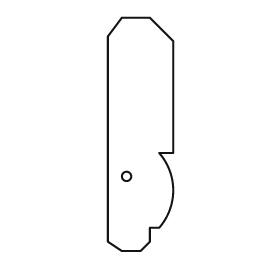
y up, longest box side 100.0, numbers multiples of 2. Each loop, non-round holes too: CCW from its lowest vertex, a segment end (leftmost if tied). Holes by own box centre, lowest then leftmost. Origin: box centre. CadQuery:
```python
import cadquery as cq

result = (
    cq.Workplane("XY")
    .moveTo(-8.0, -50.0)
    .lineTo(0.0, -50.0)
    .lineTo(4.0, -46.0)
    .lineTo(4.0, -40.0)
    .lineTo(8.0, -40.0)
    .threePointArc((14.0, -24.0), (8.0, -8.0))
    .lineTo(14.0, -8.0)
    .lineTo(14.0, 40.0)
    .lineTo(4.0, 50.0)
    .lineTo(-8.0, 50.0)
    .lineTo(-14.0, 42.0)
    .lineTo(-14.0, -46.0)
    .close()
    .moveTo(-6.0, -18.0)
    .circle(2.0)
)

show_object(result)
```